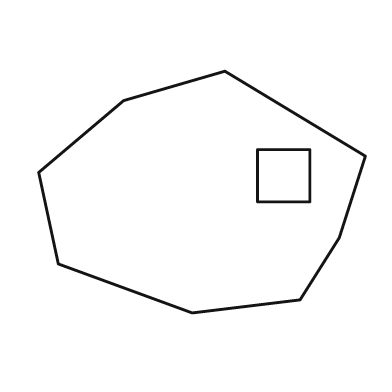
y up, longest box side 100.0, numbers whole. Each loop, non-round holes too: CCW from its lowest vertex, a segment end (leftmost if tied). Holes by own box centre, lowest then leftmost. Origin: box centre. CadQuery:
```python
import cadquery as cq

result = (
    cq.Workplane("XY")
    .moveTo(-3.0, -37.0)
    .lineTo(30.0, -33.0)
    .lineTo(42.0, -14.0)
    .lineTo(50.0, 11.0)
    .lineTo(7.0, 37.0)
    .lineTo(-24.0, 28.0)
    .lineTo(-50.0, 6.0)
    .lineTo(-44.0, -22.0)
    .close()
    .moveTo(17.0, -3.0)
    .lineTo(33.0, -3.0)
    .lineTo(33.0, 13.0)
    .lineTo(17.0, 13.0)
    .close()
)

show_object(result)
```